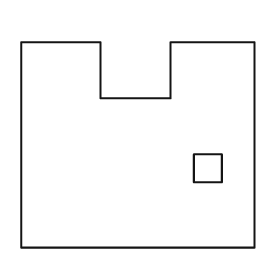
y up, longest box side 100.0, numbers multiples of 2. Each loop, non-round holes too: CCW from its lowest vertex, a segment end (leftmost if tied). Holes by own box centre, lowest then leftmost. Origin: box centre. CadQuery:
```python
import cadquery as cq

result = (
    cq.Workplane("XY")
    .moveTo(-50.0, -44.0)
    .lineTo(50.0, -44.0)
    .lineTo(50.0, 44.0)
    .lineTo(14.0, 44.0)
    .lineTo(14.0, 20.0)
    .lineTo(-16.0, 20.0)
    .lineTo(-16.0, 44.0)
    .lineTo(-50.0, 44.0)
    .close()
    .moveTo(24.0, -16.0)
    .lineTo(36.0, -16.0)
    .lineTo(36.0, -4.0)
    .lineTo(24.0, -4.0)
    .close()
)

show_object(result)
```